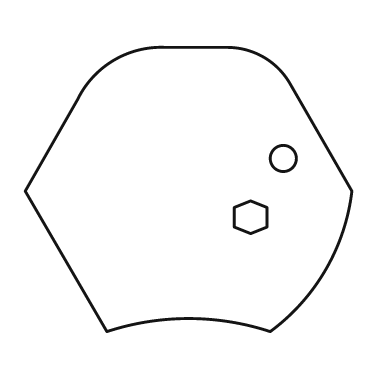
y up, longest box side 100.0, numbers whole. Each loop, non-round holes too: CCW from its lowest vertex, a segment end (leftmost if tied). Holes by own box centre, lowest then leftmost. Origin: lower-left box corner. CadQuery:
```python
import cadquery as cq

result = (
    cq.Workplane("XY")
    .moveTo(25.0, 0.0)
    .threePointArc((50.0, 4.0), (75.0, 0.0))
    .threePointArc((92.0, 19.0), (100.0, 43.0))
    .lineTo(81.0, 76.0)
    .threePointArc((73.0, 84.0), (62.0, 87.0))
    .lineTo(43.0, 87.0)
    .threePointArc((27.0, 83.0), (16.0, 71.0))
    .lineTo(0.0, 43.0)
    .close()
    .moveTo(69.0, 30.0)
    .lineTo(74.0, 32.0)
    .lineTo(74.0, 38.0)
    .lineTo(69.0, 40.0)
    .lineTo(64.0, 38.0)
    .lineTo(64.0, 32.0)
    .close()
    .moveTo(79.0, 53.0)
    .circle(4.0)
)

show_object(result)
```